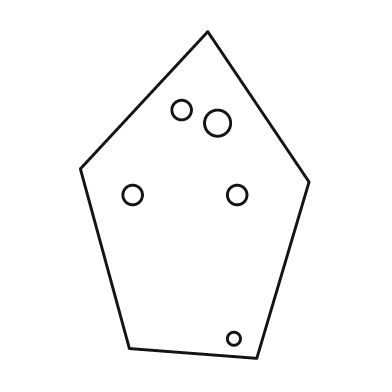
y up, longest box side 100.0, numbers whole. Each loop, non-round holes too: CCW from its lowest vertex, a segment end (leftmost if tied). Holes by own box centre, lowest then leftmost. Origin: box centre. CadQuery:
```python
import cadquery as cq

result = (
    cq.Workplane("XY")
    .moveTo(19.0, -50.0)
    .lineTo(35.0, 4.0)
    .lineTo(4.0, 50.0)
    .lineTo(-35.0, 8.0)
    .lineTo(-20.0, -47.0)
    .close()
    .moveTo(12.0, -44.0)
    .circle(2.0)
    .moveTo(-19.0, 0.0)
    .circle(3.0)
    .moveTo(13.0, 0.0)
    .circle(3.0)
    .moveTo(7.0, 22.0)
    .circle(4.0)
    .moveTo(-4.0, 26.0)
    .circle(3.0)
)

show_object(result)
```